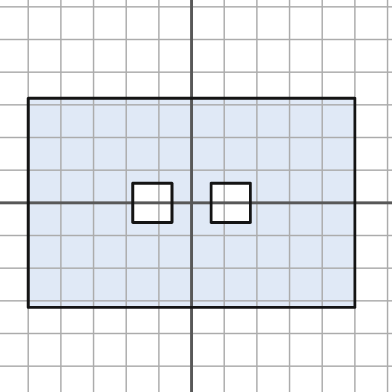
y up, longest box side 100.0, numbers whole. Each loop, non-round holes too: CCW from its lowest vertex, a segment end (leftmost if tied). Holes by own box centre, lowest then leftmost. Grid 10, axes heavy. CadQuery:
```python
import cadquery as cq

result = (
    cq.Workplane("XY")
    .moveTo(-50.0, -32.0)
    .lineTo(50.0, -32.0)
    .lineTo(50.0, 32.0)
    .lineTo(-50.0, 32.0)
    .close()
    .moveTo(-18.0, -6.0)
    .lineTo(-6.0, -6.0)
    .lineTo(-6.0, 6.0)
    .lineTo(-18.0, 6.0)
    .close()
    .moveTo(6.0, -6.0)
    .lineTo(18.0, -6.0)
    .lineTo(18.0, 6.0)
    .lineTo(6.0, 6.0)
    .close()
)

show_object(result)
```